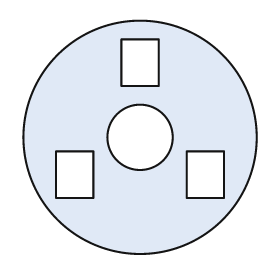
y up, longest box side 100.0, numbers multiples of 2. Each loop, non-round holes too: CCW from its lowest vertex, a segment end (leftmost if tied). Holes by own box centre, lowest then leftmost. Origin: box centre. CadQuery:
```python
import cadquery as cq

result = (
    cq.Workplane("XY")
    .moveTo(0.0, 0.0)
    .circle(50.0)
    .moveTo(-36.0, -26.0)
    .lineTo(-20.0, -26.0)
    .lineTo(-20.0, -6.0)
    .lineTo(-36.0, -6.0)
    .close()
    .moveTo(20.0, -26.0)
    .lineTo(36.0, -26.0)
    .lineTo(36.0, -6.0)
    .lineTo(20.0, -6.0)
    .close()
    .moveTo(0.0, 0.0)
    .circle(14.0)
    .moveTo(-8.0, 22.0)
    .lineTo(8.0, 22.0)
    .lineTo(8.0, 42.0)
    .lineTo(-8.0, 42.0)
    .close()
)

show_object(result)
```